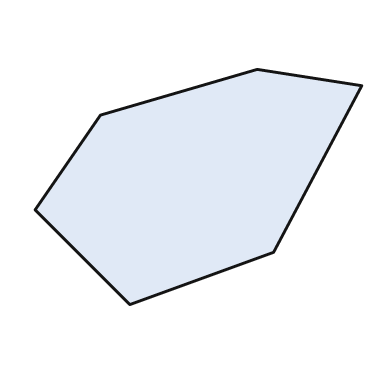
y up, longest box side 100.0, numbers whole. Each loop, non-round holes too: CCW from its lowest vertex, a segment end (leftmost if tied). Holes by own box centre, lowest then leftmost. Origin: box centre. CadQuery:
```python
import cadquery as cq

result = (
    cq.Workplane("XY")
    .moveTo(-21.0, -36.0)
    .lineTo(23.0, -20.0)
    .lineTo(50.0, 31.0)
    .lineTo(18.0, 36.0)
    .lineTo(-30.0, 22.0)
    .lineTo(-50.0, -7.0)
    .close()
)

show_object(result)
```